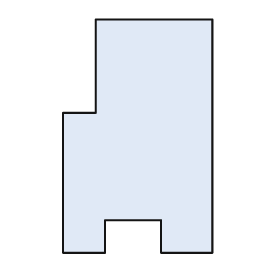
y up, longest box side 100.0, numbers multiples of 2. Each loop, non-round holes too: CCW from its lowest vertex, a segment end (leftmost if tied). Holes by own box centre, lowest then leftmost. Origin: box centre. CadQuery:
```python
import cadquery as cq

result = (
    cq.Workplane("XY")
    .moveTo(-32.0, -50.0)
    .lineTo(-14.0, -50.0)
    .lineTo(-14.0, -36.0)
    .lineTo(10.0, -36.0)
    .lineTo(10.0, -50.0)
    .lineTo(32.0, -50.0)
    .lineTo(32.0, 50.0)
    .lineTo(-18.0, 50.0)
    .lineTo(-18.0, 10.0)
    .lineTo(-32.0, 10.0)
    .close()
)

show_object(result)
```